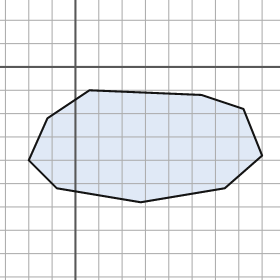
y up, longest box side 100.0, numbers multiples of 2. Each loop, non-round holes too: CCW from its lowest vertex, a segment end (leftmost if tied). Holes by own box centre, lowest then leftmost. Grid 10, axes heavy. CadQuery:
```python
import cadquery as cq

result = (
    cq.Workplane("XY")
    .moveTo(28.0, -58.0)
    .lineTo(64.0, -52.0)
    .lineTo(80.0, -38.0)
    .lineTo(72.0, -18.0)
    .lineTo(54.0, -12.0)
    .lineTo(6.0, -10.0)
    .lineTo(-12.0, -22.0)
    .lineTo(-20.0, -40.0)
    .lineTo(-8.0, -52.0)
    .close()
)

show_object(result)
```